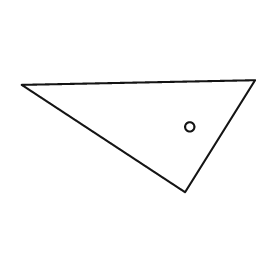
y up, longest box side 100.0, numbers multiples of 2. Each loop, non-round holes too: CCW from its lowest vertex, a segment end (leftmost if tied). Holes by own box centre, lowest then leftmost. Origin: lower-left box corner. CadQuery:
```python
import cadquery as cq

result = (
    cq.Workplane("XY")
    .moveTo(70.0, 0.0)
    .lineTo(100.0, 48.0)
    .lineTo(0.0, 46.0)
    .close()
    .moveTo(72.0, 28.0)
    .circle(2.0)
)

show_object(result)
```